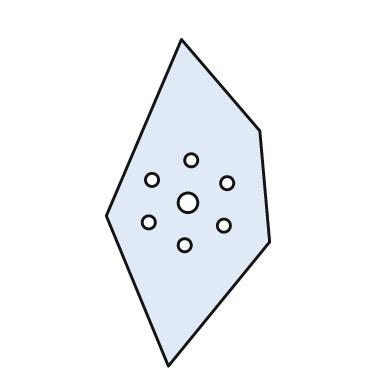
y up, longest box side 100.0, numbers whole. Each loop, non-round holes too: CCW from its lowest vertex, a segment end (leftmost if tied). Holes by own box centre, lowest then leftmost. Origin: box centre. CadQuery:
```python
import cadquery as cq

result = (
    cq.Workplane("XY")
    .moveTo(-6.0, -50.0)
    .lineTo(25.0, -12.0)
    .lineTo(22.0, 22.0)
    .lineTo(-2.0, 50.0)
    .lineTo(-25.0, -4.0)
    .close()
    .moveTo(-1.0, -13.0)
    .circle(2.0)
    .moveTo(11.0, -7.0)
    .circle(2.0)
    .moveTo(-12.0, -6.0)
    .circle(2.0)
    .moveTo(0.0, 0.0)
    .circle(3.0)
    .moveTo(12.0, 6.0)
    .circle(2.0)
    .moveTo(-11.0, 7.0)
    .circle(2.0)
    .moveTo(1.0, 13.0)
    .circle(2.0)
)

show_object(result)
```